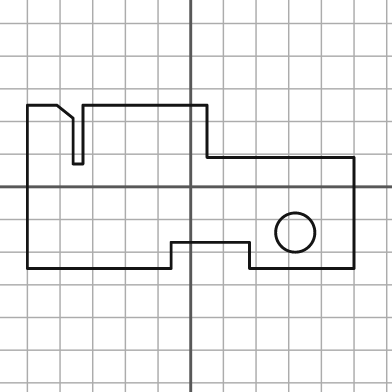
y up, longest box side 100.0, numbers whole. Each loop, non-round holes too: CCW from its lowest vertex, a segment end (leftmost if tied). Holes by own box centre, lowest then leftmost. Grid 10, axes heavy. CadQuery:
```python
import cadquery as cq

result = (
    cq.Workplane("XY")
    .moveTo(-50.0, -25.0)
    .lineTo(-6.0, -25.0)
    .lineTo(-6.0, -17.0)
    .lineTo(18.0, -17.0)
    .lineTo(18.0, -25.0)
    .lineTo(50.0, -25.0)
    .lineTo(50.0, 9.0)
    .lineTo(5.0, 9.0)
    .lineTo(5.0, 25.0)
    .lineTo(-33.0, 25.0)
    .lineTo(-33.0, 7.0)
    .lineTo(-36.0, 7.0)
    .lineTo(-36.0, 21.0)
    .lineTo(-41.0, 25.0)
    .lineTo(-50.0, 25.0)
    .close()
    .moveTo(32.0, -14.0)
    .circle(6.0)
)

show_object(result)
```